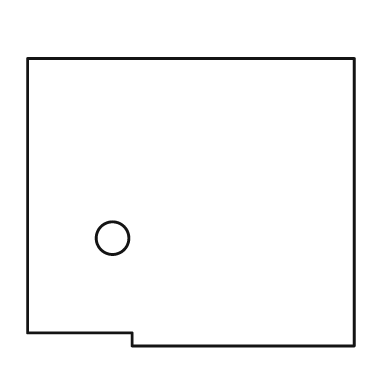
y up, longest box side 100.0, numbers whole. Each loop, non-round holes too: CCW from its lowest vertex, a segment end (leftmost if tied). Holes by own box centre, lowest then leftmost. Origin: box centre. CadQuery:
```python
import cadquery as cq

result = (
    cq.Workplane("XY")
    .moveTo(-18.0, -44.0)
    .lineTo(50.0, -44.0)
    .lineTo(50.0, 44.0)
    .lineTo(-50.0, 44.0)
    .lineTo(-50.0, -40.0)
    .lineTo(-18.0, -40.0)
    .close()
    .moveTo(-24.0, -11.0)
    .circle(5.0)
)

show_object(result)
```